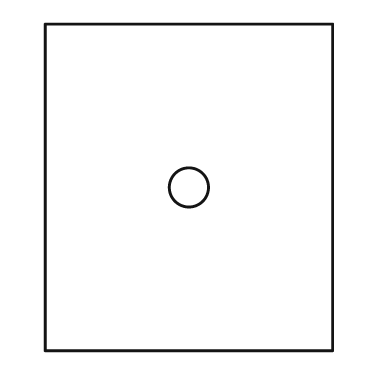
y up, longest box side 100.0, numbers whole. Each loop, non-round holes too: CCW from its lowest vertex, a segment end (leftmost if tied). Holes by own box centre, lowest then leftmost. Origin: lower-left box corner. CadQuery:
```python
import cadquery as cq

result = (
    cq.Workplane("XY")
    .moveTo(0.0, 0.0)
    .lineTo(88.0, 0.0)
    .lineTo(88.0, 100.0)
    .lineTo(0.0, 100.0)
    .close()
    .moveTo(44.0, 50.0)
    .circle(6.0)
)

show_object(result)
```